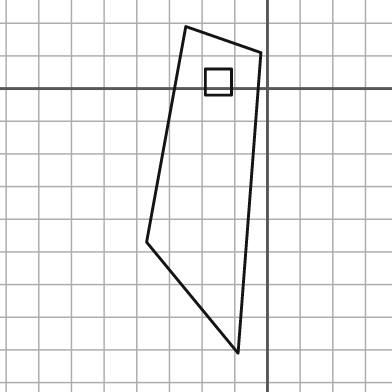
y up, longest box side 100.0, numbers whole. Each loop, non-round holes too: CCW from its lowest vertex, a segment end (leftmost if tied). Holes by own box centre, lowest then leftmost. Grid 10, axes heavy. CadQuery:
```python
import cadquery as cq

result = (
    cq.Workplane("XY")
    .moveTo(-9.0, -81.0)
    .lineTo(-2.0, 11.0)
    .lineTo(-25.0, 19.0)
    .lineTo(-37.0, -47.0)
    .close()
    .moveTo(-19.0, -2.0)
    .lineTo(-11.0, -2.0)
    .lineTo(-11.0, 6.0)
    .lineTo(-19.0, 6.0)
    .close()
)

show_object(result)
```